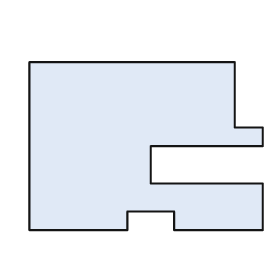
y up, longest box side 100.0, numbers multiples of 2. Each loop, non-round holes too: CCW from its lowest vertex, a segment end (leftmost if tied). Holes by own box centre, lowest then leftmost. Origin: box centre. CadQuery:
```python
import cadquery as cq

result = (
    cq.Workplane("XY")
    .moveTo(-50.0, -36.0)
    .lineTo(-8.0, -36.0)
    .lineTo(-8.0, -28.0)
    .lineTo(12.0, -28.0)
    .lineTo(12.0, -36.0)
    .lineTo(50.0, -36.0)
    .lineTo(50.0, -16.0)
    .lineTo(2.0, -16.0)
    .lineTo(2.0, 0.0)
    .lineTo(50.0, 0.0)
    .lineTo(50.0, 8.0)
    .lineTo(38.0, 8.0)
    .lineTo(38.0, 36.0)
    .lineTo(-50.0, 36.0)
    .close()
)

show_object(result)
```